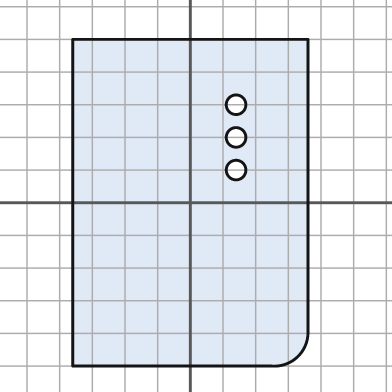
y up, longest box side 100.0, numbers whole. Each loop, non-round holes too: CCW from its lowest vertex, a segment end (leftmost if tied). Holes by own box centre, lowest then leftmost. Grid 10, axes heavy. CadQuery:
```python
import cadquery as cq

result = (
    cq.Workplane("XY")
    .moveTo(-36.0, -50.0)
    .lineTo(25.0, -50.0)
    .threePointArc((33.0, -47.0), (36.0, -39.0))
    .lineTo(36.0, 50.0)
    .lineTo(-36.0, 50.0)
    .close()
    .moveTo(14.0, 10.0)
    .circle(3.0)
    .moveTo(14.0, 20.0)
    .circle(3.0)
    .moveTo(14.0, 30.0)
    .circle(3.0)
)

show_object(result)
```